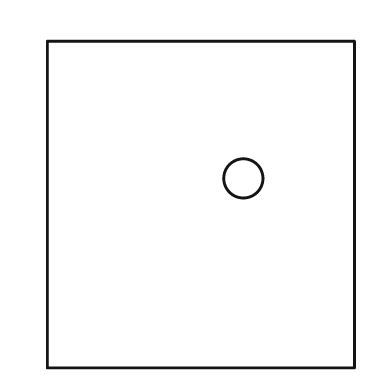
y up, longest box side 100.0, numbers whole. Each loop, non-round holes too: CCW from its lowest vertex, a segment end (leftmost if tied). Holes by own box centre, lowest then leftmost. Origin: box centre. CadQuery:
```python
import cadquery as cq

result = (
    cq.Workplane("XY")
    .moveTo(-47.0, -50.0)
    .lineTo(47.0, -50.0)
    .lineTo(47.0, 50.0)
    .lineTo(-47.0, 50.0)
    .close()
    .moveTo(13.0, 8.0)
    .circle(6.0)
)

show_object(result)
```